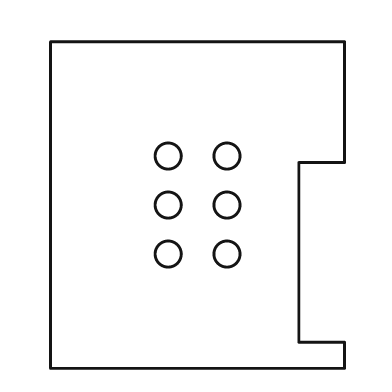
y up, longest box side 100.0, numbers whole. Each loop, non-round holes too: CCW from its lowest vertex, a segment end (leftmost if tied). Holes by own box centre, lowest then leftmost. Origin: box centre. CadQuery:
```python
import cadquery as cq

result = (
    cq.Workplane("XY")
    .moveTo(-45.0, -50.0)
    .lineTo(45.0, -50.0)
    .lineTo(45.0, -42.0)
    .lineTo(31.0, -42.0)
    .lineTo(31.0, 13.0)
    .lineTo(45.0, 13.0)
    .lineTo(45.0, 50.0)
    .lineTo(-45.0, 50.0)
    .close()
    .moveTo(-9.0, -15.0)
    .circle(4.0)
    .moveTo(9.0, -15.0)
    .circle(4.0)
    .moveTo(-9.0, 0.0)
    .circle(4.0)
    .moveTo(9.0, 0.0)
    .circle(4.0)
    .moveTo(-9.0, 15.0)
    .circle(4.0)
    .moveTo(9.0, 15.0)
    .circle(4.0)
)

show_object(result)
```